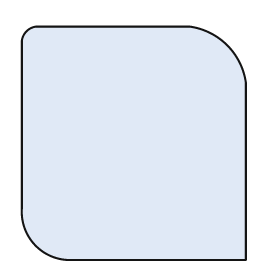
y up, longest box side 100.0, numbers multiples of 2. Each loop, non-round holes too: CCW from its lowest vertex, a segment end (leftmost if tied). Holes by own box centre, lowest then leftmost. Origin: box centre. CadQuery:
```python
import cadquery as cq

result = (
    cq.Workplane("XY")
    .moveTo(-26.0, -50.0)
    .lineTo(48.0, -50.0)
    .lineTo(48.0, 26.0)
    .threePointArc((40.0, 42.0), (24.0, 50.0))
    .lineTo(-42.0, 50.0)
    .threePointArc((-46.0, 48.0), (-48.0, 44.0))
    .lineTo(-48.0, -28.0)
    .threePointArc((-42.0, -44.0), (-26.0, -50.0))
    .close()
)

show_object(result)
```